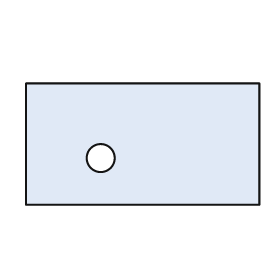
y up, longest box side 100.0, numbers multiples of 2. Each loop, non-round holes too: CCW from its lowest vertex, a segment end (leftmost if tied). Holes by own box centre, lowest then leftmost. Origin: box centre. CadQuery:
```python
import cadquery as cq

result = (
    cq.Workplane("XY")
    .moveTo(-50.0, -26.0)
    .lineTo(50.0, -26.0)
    .lineTo(50.0, 26.0)
    .lineTo(-50.0, 26.0)
    .close()
    .moveTo(-18.0, -6.0)
    .circle(6.0)
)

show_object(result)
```